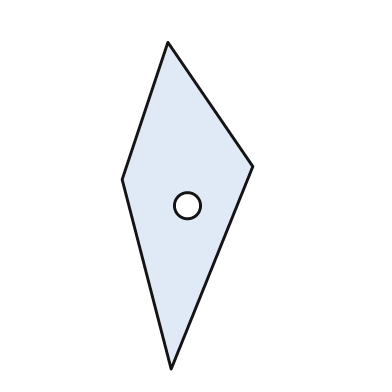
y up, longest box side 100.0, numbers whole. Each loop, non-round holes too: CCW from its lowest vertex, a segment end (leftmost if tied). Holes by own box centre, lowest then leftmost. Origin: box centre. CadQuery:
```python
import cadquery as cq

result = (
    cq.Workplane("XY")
    .moveTo(-5.0, -50.0)
    .lineTo(20.0, 12.0)
    .lineTo(-6.0, 50.0)
    .lineTo(-20.0, 8.0)
    .close()
    .moveTo(0.0, 0.0)
    .circle(4.0)
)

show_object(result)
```